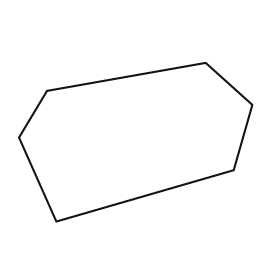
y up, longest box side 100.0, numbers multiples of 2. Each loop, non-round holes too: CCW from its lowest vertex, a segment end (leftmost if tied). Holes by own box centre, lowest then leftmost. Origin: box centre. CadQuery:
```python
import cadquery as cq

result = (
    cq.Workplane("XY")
    .moveTo(-34.0, -34.0)
    .lineTo(42.0, -12.0)
    .lineTo(50.0, 16.0)
    .lineTo(30.0, 34.0)
    .lineTo(-38.0, 22.0)
    .lineTo(-50.0, 2.0)
    .close()
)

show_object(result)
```